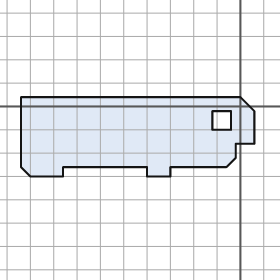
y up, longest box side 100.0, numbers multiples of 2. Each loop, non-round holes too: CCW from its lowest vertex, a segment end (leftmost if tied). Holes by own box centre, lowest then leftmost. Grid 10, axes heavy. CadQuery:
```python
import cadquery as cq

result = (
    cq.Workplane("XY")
    .moveTo(-90.0, -30.0)
    .lineTo(-76.0, -30.0)
    .lineTo(-76.0, -26.0)
    .lineTo(-40.0, -26.0)
    .lineTo(-40.0, -30.0)
    .lineTo(-30.0, -30.0)
    .lineTo(-30.0, -26.0)
    .lineTo(-6.0, -26.0)
    .lineTo(-2.0, -22.0)
    .lineTo(-2.0, -16.0)
    .lineTo(6.0, -16.0)
    .lineTo(6.0, -2.0)
    .lineTo(0.0, 4.0)
    .lineTo(-94.0, 4.0)
    .lineTo(-94.0, -26.0)
    .close()
    .moveTo(-12.0, -10.0)
    .lineTo(-4.0, -10.0)
    .lineTo(-4.0, -2.0)
    .lineTo(-12.0, -2.0)
    .close()
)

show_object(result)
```